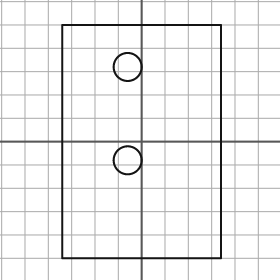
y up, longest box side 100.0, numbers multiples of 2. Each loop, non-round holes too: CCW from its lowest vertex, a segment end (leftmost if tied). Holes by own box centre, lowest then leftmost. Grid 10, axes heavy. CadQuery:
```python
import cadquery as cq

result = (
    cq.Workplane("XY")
    .moveTo(-34.0, -50.0)
    .lineTo(34.0, -50.0)
    .lineTo(34.0, 50.0)
    .lineTo(-34.0, 50.0)
    .close()
    .moveTo(-6.0, -8.0)
    .circle(6.0)
    .moveTo(-6.0, 32.0)
    .circle(6.0)
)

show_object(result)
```